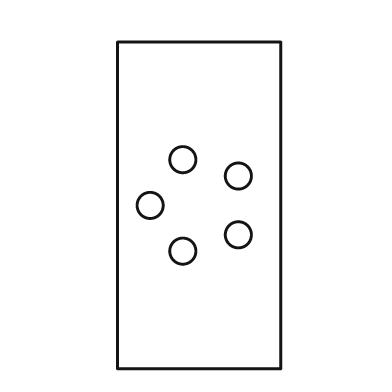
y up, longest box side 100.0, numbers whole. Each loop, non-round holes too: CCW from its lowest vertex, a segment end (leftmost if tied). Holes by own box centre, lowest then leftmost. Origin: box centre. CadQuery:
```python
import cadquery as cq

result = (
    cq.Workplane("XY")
    .moveTo(-25.0, -50.0)
    .lineTo(25.0, -50.0)
    .lineTo(25.0, 50.0)
    .lineTo(-25.0, 50.0)
    .close()
    .moveTo(-5.0, -14.0)
    .circle(4.0)
    .moveTo(12.0, -9.0)
    .circle(4.0)
    .moveTo(-15.0, 0.0)
    .circle(4.0)
    .moveTo(12.0, 9.0)
    .circle(4.0)
    .moveTo(-5.0, 14.0)
    .circle(4.0)
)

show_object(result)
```